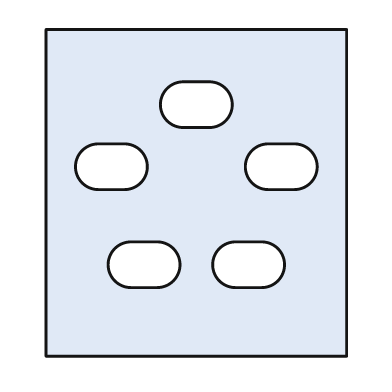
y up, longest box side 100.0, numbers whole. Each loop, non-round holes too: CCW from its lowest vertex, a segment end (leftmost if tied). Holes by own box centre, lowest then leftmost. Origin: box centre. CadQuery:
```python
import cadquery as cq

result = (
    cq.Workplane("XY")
    .moveTo(-46.0, -50.0)
    .lineTo(46.0, -50.0)
    .lineTo(46.0, 50.0)
    .lineTo(-46.0, 50.0)
    .close()
    .moveTo(-20.0, -29.0)
    .lineTo(-12.0, -29.0)
    .threePointArc((-5.0, -22.0), (-12.0, -15.0))
    .lineTo(-20.0, -15.0)
    .threePointArc((-27.0, -22.0), (-20.0, -29.0))
    .close()
    .moveTo(12.0, -29.0)
    .lineTo(20.0, -29.0)
    .threePointArc((27.0, -22.0), (20.0, -15.0))
    .lineTo(12.0, -15.0)
    .threePointArc((5.0, -22.0), (12.0, -29.0))
    .close()
    .moveTo(-30.0, 1.0)
    .lineTo(-22.0, 1.0)
    .threePointArc((-15.0, 8.0), (-22.0, 15.0))
    .lineTo(-30.0, 15.0)
    .threePointArc((-37.0, 8.0), (-30.0, 1.0))
    .close()
    .moveTo(22.0, 1.0)
    .lineTo(30.0, 1.0)
    .threePointArc((37.0, 8.0), (30.0, 15.0))
    .lineTo(22.0, 15.0)
    .threePointArc((15.0, 8.0), (22.0, 1.0))
    .close()
    .moveTo(-4.0, 20.0)
    .lineTo(4.0, 20.0)
    .threePointArc((11.0, 27.0), (4.0, 34.0))
    .lineTo(-4.0, 34.0)
    .threePointArc((-11.0, 27.0), (-4.0, 20.0))
    .close()
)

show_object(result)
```